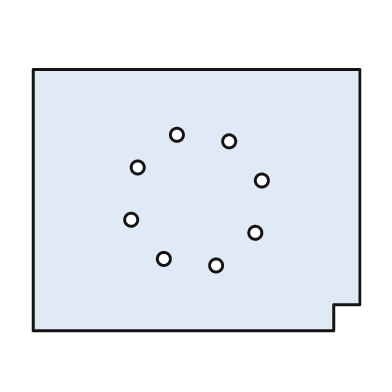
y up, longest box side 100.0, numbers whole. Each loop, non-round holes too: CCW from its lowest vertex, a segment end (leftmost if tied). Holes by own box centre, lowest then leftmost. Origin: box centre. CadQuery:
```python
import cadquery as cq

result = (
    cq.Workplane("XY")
    .moveTo(-50.0, -40.0)
    .lineTo(42.0, -40.0)
    .lineTo(42.0, -32.0)
    .lineTo(50.0, -32.0)
    .lineTo(50.0, 40.0)
    .lineTo(-50.0, 40.0)
    .close()
    .moveTo(6.0, -20.0)
    .circle(2.0)
    .moveTo(-10.0, -18.0)
    .circle(2.0)
    .moveTo(18.0, -10.0)
    .circle(2.0)
    .moveTo(-20.0, -6.0)
    .circle(2.0)
    .moveTo(20.0, 6.0)
    .circle(2.0)
    .moveTo(-18.0, 10.0)
    .circle(2.0)
    .moveTo(10.0, 18.0)
    .circle(2.0)
    .moveTo(-6.0, 20.0)
    .circle(2.0)
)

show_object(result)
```